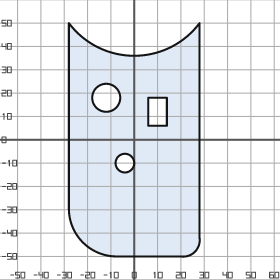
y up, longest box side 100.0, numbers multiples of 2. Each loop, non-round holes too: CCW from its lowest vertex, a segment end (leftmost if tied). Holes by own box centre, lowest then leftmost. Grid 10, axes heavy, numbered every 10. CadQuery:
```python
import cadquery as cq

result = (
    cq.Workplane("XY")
    .moveTo(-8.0, -50.0)
    .lineTo(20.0, -50.0)
    .threePointArc((26.0, -48.0), (28.0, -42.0))
    .lineTo(28.0, 50.0)
    .threePointArc((0.0, 36.0), (-28.0, 50.0))
    .lineTo(-28.0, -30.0)
    .threePointArc((-22.0, -44.0), (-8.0, -50.0))
    .close()
    .moveTo(-4.0, -10.0)
    .circle(4.0)
    .moveTo(6.0, 6.0)
    .lineTo(14.0, 6.0)
    .lineTo(14.0, 18.0)
    .lineTo(6.0, 18.0)
    .close()
    .moveTo(-12.0, 18.0)
    .circle(6.0)
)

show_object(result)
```